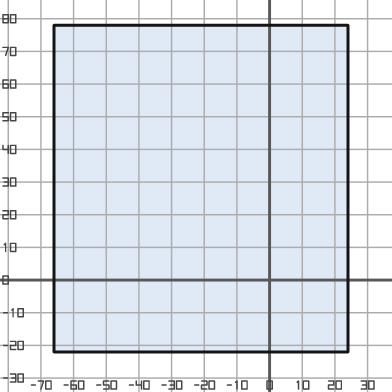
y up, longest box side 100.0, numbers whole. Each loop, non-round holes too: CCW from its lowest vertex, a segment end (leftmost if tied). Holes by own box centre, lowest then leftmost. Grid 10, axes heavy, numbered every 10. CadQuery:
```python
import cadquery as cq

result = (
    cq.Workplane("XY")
    .moveTo(-66.0, -22.0)
    .lineTo(24.0, -22.0)
    .lineTo(24.0, 78.0)
    .lineTo(-66.0, 78.0)
    .close()
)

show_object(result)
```